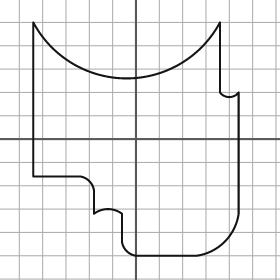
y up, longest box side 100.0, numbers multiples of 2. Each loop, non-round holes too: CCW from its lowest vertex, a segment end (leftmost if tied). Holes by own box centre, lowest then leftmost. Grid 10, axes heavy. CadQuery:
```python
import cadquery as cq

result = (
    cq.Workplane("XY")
    .moveTo(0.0, -50.0)
    .lineTo(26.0, -50.0)
    .threePointArc((38.0, -44.0), (44.0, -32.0))
    .lineTo(44.0, 20.0)
    .threePointArc((40.0, 18.0), (36.0, 20.0))
    .lineTo(36.0, 50.0)
    .threePointArc((-4.0, 26.0), (-44.0, 50.0))
    .lineTo(-44.0, -16.0)
    .lineTo(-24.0, -16.0)
    .threePointArc((-20.0, -18.0), (-18.0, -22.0))
    .lineTo(-18.0, -32.0)
    .threePointArc((-12.0, -30.0), (-6.0, -32.0))
    .lineTo(-6.0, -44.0)
    .threePointArc((-4.0, -48.0), (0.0, -50.0))
    .close()
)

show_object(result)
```